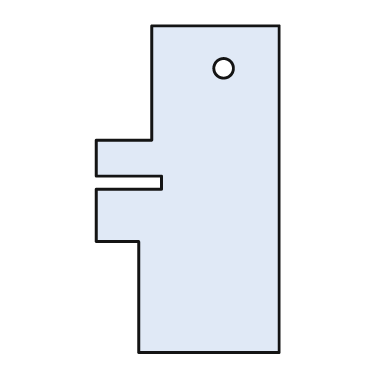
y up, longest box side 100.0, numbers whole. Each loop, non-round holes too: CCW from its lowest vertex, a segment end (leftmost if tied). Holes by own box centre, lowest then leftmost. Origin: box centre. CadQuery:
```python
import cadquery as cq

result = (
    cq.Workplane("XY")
    .moveTo(-15.0, -50.0)
    .lineTo(28.0, -50.0)
    .lineTo(28.0, 50.0)
    .lineTo(-11.0, 50.0)
    .lineTo(-11.0, 15.0)
    .lineTo(-28.0, 15.0)
    .lineTo(-28.0, 4.0)
    .lineTo(-8.0, 4.0)
    .lineTo(-8.0, 0.0)
    .lineTo(-28.0, 0.0)
    .lineTo(-28.0, -16.0)
    .lineTo(-15.0, -16.0)
    .close()
    .moveTo(11.0, 37.0)
    .circle(3.0)
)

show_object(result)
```